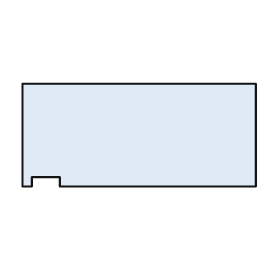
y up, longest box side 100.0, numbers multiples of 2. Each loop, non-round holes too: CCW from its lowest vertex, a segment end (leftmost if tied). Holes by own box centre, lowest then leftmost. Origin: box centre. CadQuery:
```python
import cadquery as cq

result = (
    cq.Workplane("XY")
    .moveTo(-50.0, -22.0)
    .lineTo(-46.0, -22.0)
    .lineTo(-46.0, -18.0)
    .lineTo(-34.0, -18.0)
    .lineTo(-34.0, -22.0)
    .lineTo(50.0, -22.0)
    .lineTo(50.0, 22.0)
    .lineTo(-50.0, 22.0)
    .close()
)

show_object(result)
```